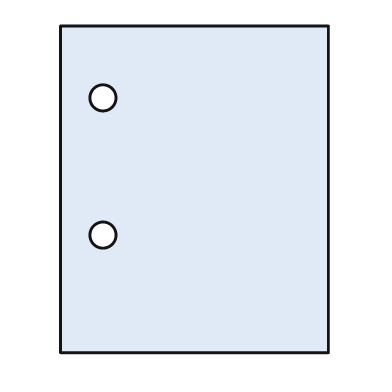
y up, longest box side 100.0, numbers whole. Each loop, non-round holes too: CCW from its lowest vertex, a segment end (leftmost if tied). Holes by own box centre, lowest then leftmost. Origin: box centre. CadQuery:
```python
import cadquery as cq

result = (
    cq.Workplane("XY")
    .moveTo(-41.0, -50.0)
    .lineTo(41.0, -50.0)
    .lineTo(41.0, 50.0)
    .lineTo(-41.0, 50.0)
    .close()
    .moveTo(-28.0, -14.0)
    .circle(4.0)
    .moveTo(-28.0, 28.0)
    .circle(4.0)
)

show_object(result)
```